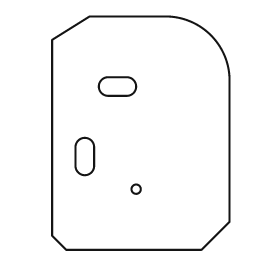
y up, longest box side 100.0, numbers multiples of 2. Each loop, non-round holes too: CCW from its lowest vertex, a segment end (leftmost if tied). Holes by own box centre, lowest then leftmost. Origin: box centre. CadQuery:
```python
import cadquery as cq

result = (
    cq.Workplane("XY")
    .moveTo(-32.0, -50.0)
    .lineTo(26.0, -50.0)
    .lineTo(38.0, -38.0)
    .lineTo(38.0, 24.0)
    .threePointArc((30.0, 42.0), (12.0, 50.0))
    .lineTo(-22.0, 50.0)
    .lineTo(-38.0, 40.0)
    .lineTo(-38.0, -44.0)
    .close()
    .moveTo(-2.0, -24.0)
    .circle(2.0)
    .moveTo(-28.0, -14.0)
    .threePointArc((-24.0, -18.0), (-20.0, -14.0))
    .lineTo(-20.0, -6.0)
    .threePointArc((-24.0, -2.0), (-28.0, -6.0))
    .close()
    .moveTo(-14.0, 16.0)
    .lineTo(-6.0, 16.0)
    .threePointArc((-2.0, 20.0), (-6.0, 24.0))
    .lineTo(-14.0, 24.0)
    .threePointArc((-18.0, 20.0), (-14.0, 16.0))
    .close()
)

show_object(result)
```